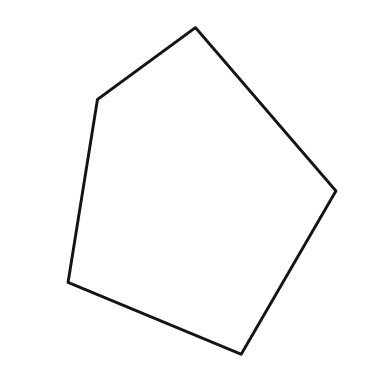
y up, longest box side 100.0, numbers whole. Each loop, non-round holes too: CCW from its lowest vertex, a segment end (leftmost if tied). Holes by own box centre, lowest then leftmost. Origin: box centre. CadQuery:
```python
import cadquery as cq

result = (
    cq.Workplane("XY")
    .moveTo(12.0, -50.0)
    .lineTo(41.0, 0.0)
    .lineTo(-2.0, 50.0)
    .lineTo(-32.0, 28.0)
    .lineTo(-41.0, -28.0)
    .close()
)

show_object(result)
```